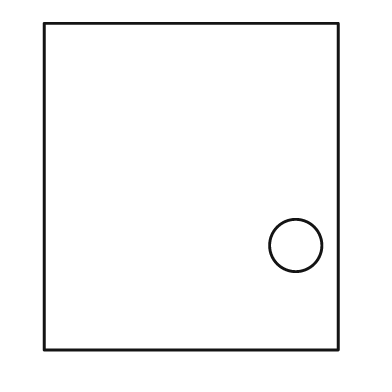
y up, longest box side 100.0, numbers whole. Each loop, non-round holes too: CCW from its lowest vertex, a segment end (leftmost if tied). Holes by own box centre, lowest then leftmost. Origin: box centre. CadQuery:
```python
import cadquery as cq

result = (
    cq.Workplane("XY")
    .moveTo(-45.0, -50.0)
    .lineTo(45.0, -50.0)
    .lineTo(45.0, 50.0)
    .lineTo(-45.0, 50.0)
    .close()
    .moveTo(32.0, -18.0)
    .circle(8.0)
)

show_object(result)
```